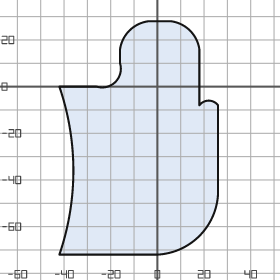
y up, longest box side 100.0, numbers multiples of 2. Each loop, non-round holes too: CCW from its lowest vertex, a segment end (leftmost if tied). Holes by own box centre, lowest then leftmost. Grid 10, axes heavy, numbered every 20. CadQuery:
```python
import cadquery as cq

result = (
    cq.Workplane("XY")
    .moveTo(-42.0, -72.0)
    .lineTo(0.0, -72.0)
    .threePointArc((18.0, -64.0), (26.0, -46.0))
    .lineTo(26.0, -8.0)
    .threePointArc((22.0, -6.0), (18.0, -8.0))
    .lineTo(18.0, 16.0)
    .threePointArc((14.0, 24.0), (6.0, 28.0))
    .lineTo(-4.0, 28.0)
    .threePointArc((-12.0, 24.0), (-16.0, 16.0))
    .lineTo(-16.0, 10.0)
    .threePointArc((-18.0, 2.0), (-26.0, 0.0))
    .lineTo(-42.0, 0.0)
    .threePointArc((-36.0, -36.0), (-42.0, -72.0))
    .close()
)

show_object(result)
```